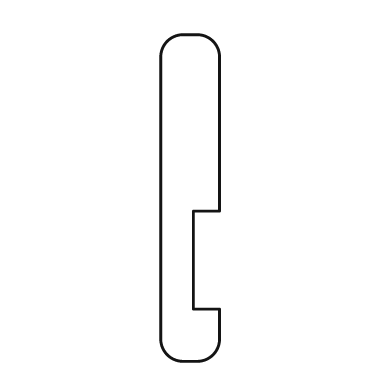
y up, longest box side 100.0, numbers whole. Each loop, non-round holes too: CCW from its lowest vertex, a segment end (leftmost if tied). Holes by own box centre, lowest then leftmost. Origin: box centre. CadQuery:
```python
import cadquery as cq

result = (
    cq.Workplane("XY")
    .moveTo(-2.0, -50.0)
    .lineTo(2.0, -50.0)
    .threePointArc((7.0, -48.0), (9.0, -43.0))
    .lineTo(9.0, -34.0)
    .lineTo(1.0, -34.0)
    .lineTo(1.0, -4.0)
    .lineTo(9.0, -4.0)
    .lineTo(9.0, 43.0)
    .threePointArc((7.0, 48.0), (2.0, 50.0))
    .lineTo(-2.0, 50.0)
    .threePointArc((-7.0, 48.0), (-9.0, 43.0))
    .lineTo(-9.0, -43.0)
    .threePointArc((-7.0, -48.0), (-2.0, -50.0))
    .close()
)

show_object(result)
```